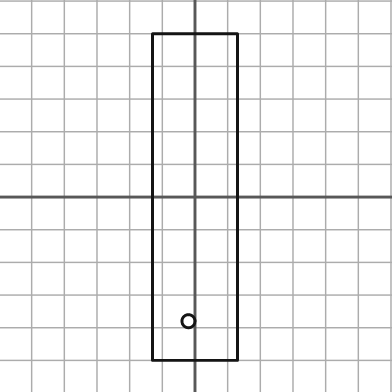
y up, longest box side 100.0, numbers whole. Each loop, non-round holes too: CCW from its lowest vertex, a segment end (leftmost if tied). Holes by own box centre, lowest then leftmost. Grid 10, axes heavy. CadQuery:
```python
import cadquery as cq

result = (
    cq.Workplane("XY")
    .moveTo(-13.0, -50.0)
    .lineTo(13.0, -50.0)
    .lineTo(13.0, 50.0)
    .lineTo(-13.0, 50.0)
    .close()
    .moveTo(-2.0, -38.0)
    .circle(2.0)
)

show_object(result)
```